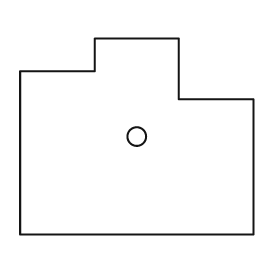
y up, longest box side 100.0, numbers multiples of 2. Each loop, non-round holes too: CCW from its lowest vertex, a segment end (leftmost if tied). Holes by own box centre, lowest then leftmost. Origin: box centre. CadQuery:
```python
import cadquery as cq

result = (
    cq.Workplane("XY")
    .moveTo(-50.0, -42.0)
    .lineTo(50.0, -42.0)
    .lineTo(50.0, 16.0)
    .lineTo(18.0, 16.0)
    .lineTo(18.0, 42.0)
    .lineTo(-18.0, 42.0)
    .lineTo(-18.0, 28.0)
    .lineTo(-50.0, 28.0)
    .close()
    .moveTo(0.0, 0.0)
    .circle(4.0)
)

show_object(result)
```